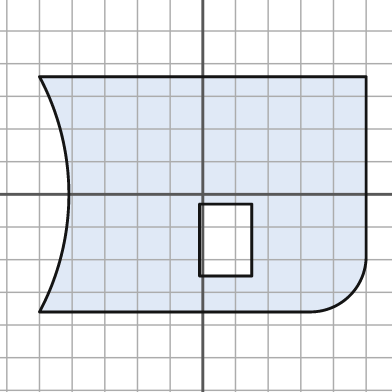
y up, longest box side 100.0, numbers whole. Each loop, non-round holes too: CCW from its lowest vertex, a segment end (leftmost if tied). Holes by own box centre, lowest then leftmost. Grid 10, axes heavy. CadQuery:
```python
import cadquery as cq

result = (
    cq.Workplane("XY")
    .moveTo(-50.0, -36.0)
    .lineTo(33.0, -36.0)
    .threePointArc((45.0, -31.0), (50.0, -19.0))
    .lineTo(50.0, 36.0)
    .lineTo(-50.0, 36.0)
    .threePointArc((-41.0, 0.0), (-50.0, -36.0))
    .close()
    .moveTo(-1.0, -25.0)
    .lineTo(15.0, -25.0)
    .lineTo(15.0, -3.0)
    .lineTo(-1.0, -3.0)
    .close()
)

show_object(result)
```